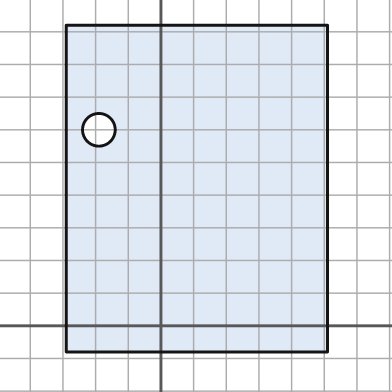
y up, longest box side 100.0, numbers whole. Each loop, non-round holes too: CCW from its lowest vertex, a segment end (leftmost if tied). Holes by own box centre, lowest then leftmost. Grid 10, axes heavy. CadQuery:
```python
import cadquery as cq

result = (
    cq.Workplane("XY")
    .moveTo(-29.0, -8.0)
    .lineTo(51.0, -8.0)
    .lineTo(51.0, 92.0)
    .lineTo(-29.0, 92.0)
    .close()
    .moveTo(-19.0, 60.0)
    .circle(5.0)
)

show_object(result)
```